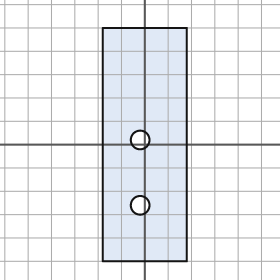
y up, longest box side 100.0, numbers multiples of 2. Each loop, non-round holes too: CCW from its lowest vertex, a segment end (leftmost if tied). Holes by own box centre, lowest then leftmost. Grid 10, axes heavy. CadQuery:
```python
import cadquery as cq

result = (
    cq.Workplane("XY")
    .moveTo(-18.0, -50.0)
    .lineTo(18.0, -50.0)
    .lineTo(18.0, 50.0)
    .lineTo(-18.0, 50.0)
    .close()
    .moveTo(-2.0, -26.0)
    .circle(4.0)
    .moveTo(-2.0, 2.0)
    .circle(4.0)
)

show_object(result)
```